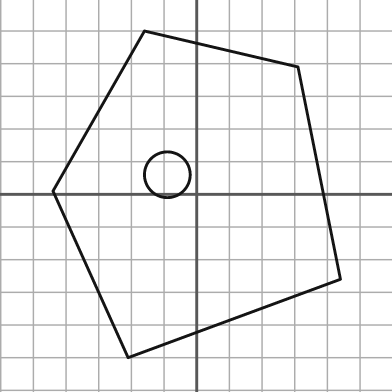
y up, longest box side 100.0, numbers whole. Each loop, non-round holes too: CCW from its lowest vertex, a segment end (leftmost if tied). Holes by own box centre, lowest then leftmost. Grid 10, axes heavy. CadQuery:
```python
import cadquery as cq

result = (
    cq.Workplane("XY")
    .moveTo(-21.0, -50.0)
    .lineTo(44.0, -26.0)
    .lineTo(31.0, 39.0)
    .lineTo(-16.0, 50.0)
    .lineTo(-44.0, 1.0)
    .close()
    .moveTo(-9.0, 6.0)
    .circle(7.0)
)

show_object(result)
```